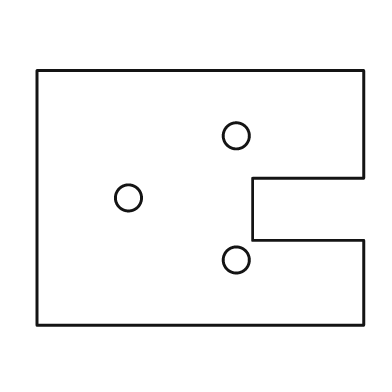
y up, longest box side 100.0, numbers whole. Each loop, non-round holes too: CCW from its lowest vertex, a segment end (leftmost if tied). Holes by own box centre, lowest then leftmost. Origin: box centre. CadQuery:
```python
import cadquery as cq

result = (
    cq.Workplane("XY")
    .moveTo(-50.0, -39.0)
    .lineTo(50.0, -39.0)
    .lineTo(50.0, -13.0)
    .lineTo(16.0, -13.0)
    .lineTo(16.0, 6.0)
    .lineTo(50.0, 6.0)
    .lineTo(50.0, 39.0)
    .lineTo(-50.0, 39.0)
    .close()
    .moveTo(11.0, -19.0)
    .circle(4.0)
    .moveTo(-22.0, 0.0)
    .circle(4.0)
    .moveTo(11.0, 19.0)
    .circle(4.0)
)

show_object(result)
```